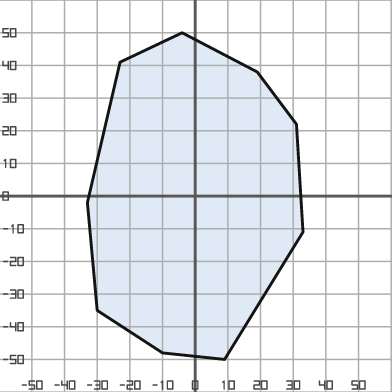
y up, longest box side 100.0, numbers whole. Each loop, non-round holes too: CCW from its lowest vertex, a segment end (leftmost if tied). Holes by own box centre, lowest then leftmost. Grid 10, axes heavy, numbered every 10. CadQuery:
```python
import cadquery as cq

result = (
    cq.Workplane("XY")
    .moveTo(9.0, -50.0)
    .lineTo(33.0, -11.0)
    .lineTo(31.0, 22.0)
    .lineTo(19.0, 38.0)
    .lineTo(-4.0, 50.0)
    .lineTo(-23.0, 41.0)
    .lineTo(-33.0, -2.0)
    .lineTo(-30.0, -35.0)
    .lineTo(-10.0, -48.0)
    .close()
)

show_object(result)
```